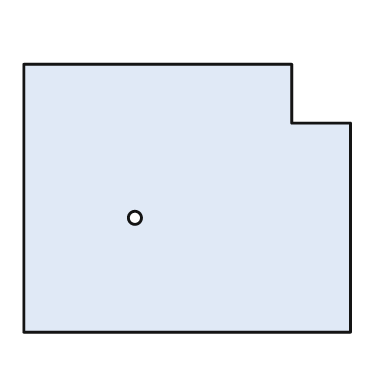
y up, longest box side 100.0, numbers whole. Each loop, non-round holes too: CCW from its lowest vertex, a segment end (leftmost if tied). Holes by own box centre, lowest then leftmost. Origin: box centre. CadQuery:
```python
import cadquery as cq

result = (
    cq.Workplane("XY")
    .moveTo(-50.0, -41.0)
    .lineTo(50.0, -41.0)
    .lineTo(50.0, 23.0)
    .lineTo(32.0, 23.0)
    .lineTo(32.0, 41.0)
    .lineTo(-50.0, 41.0)
    .close()
    .moveTo(-16.0, -6.0)
    .circle(2.0)
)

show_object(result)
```